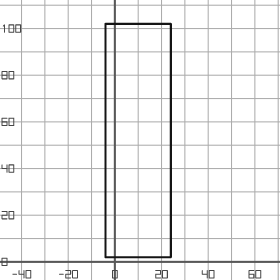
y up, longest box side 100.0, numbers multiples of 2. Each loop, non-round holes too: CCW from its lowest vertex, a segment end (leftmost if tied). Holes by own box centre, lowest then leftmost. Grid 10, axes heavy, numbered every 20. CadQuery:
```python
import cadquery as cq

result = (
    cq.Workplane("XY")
    .moveTo(-4.0, 2.0)
    .lineTo(24.0, 2.0)
    .lineTo(24.0, 102.0)
    .lineTo(-4.0, 102.0)
    .close()
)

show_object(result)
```